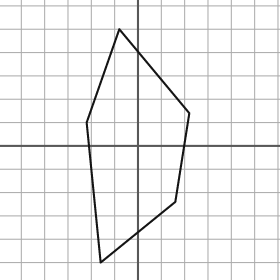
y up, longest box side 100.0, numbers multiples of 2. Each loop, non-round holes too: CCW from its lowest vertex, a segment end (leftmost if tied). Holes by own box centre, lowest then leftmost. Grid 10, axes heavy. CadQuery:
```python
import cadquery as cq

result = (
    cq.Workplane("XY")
    .moveTo(-16.0, -50.0)
    .lineTo(16.0, -24.0)
    .lineTo(22.0, 14.0)
    .lineTo(-8.0, 50.0)
    .lineTo(-22.0, 10.0)
    .close()
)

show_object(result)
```